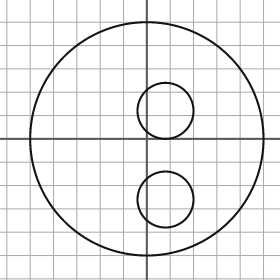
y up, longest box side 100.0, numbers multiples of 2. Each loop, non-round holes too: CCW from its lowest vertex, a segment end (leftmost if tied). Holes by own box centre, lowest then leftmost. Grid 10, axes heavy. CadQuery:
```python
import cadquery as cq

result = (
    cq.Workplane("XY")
    .moveTo(0.0, 0.0)
    .circle(50.0)
    .moveTo(8.0, -26.0)
    .circle(12.0)
    .moveTo(8.0, 12.0)
    .circle(12.0)
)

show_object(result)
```